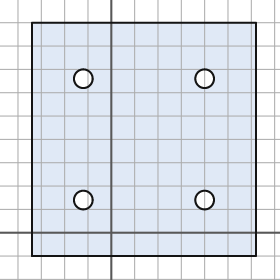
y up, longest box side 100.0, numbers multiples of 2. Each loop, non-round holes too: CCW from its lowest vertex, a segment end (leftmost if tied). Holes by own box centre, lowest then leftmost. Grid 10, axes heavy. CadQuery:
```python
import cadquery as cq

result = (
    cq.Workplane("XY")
    .moveTo(-34.0, -10.0)
    .lineTo(62.0, -10.0)
    .lineTo(62.0, 90.0)
    .lineTo(-34.0, 90.0)
    .close()
    .moveTo(-12.0, 14.0)
    .circle(4.0)
    .moveTo(40.0, 14.0)
    .circle(4.0)
    .moveTo(-12.0, 66.0)
    .circle(4.0)
    .moveTo(40.0, 66.0)
    .circle(4.0)
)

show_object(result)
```